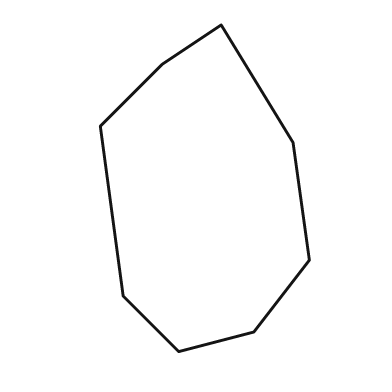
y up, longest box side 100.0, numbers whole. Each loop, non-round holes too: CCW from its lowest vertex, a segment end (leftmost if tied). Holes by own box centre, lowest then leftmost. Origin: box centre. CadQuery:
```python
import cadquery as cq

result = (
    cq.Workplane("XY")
    .moveTo(-8.0, -50.0)
    .lineTo(15.0, -44.0)
    .lineTo(32.0, -22.0)
    .lineTo(27.0, 14.0)
    .lineTo(5.0, 50.0)
    .lineTo(-13.0, 38.0)
    .lineTo(-32.0, 19.0)
    .lineTo(-25.0, -33.0)
    .close()
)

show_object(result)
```